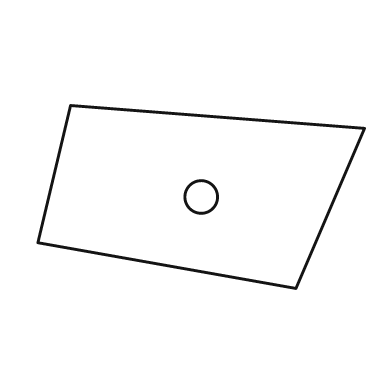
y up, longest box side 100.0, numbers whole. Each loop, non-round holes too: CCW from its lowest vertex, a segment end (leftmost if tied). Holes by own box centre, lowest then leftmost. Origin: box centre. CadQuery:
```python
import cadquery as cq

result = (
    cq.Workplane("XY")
    .moveTo(29.0, -28.0)
    .lineTo(50.0, 21.0)
    .lineTo(-40.0, 28.0)
    .lineTo(-50.0, -14.0)
    .close()
    .moveTo(0.0, 0.0)
    .circle(5.0)
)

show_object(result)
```